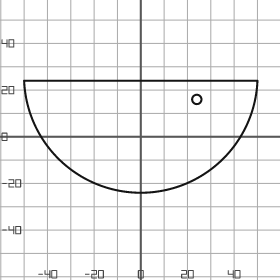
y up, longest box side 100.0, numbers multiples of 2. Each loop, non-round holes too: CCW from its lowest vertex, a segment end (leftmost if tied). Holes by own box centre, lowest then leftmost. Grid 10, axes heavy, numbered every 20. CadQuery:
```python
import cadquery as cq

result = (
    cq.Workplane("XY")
    .moveTo(-50.0, 24.0)
    .threePointArc((0.0, -24.0), (50.0, 24.0))
    .close()
    .moveTo(24.0, 16.0)
    .circle(2.0)
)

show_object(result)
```